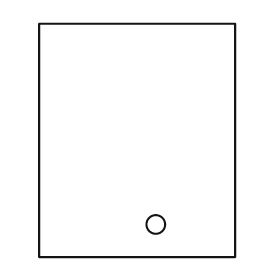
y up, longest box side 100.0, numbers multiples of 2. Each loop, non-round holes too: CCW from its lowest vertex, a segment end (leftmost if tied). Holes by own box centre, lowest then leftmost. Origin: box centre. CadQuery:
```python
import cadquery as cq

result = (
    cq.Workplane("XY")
    .moveTo(-42.0, -50.0)
    .lineTo(42.0, -50.0)
    .lineTo(42.0, 50.0)
    .lineTo(-42.0, 50.0)
    .close()
    .moveTo(8.0, -36.0)
    .circle(4.0)
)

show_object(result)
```